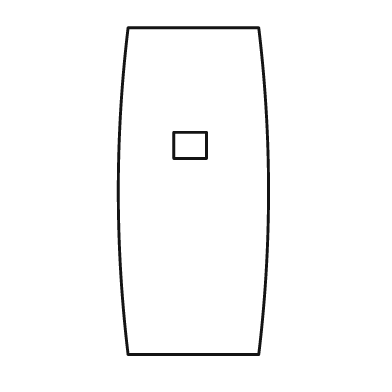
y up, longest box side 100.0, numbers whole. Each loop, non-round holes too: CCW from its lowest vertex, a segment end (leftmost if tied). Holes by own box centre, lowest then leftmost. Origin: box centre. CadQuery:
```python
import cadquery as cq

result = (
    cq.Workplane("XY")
    .moveTo(-20.0, -50.0)
    .lineTo(20.0, -50.0)
    .threePointArc((23.0, 0.0), (20.0, 50.0))
    .lineTo(-20.0, 50.0)
    .threePointArc((-23.0, 0.0), (-20.0, -50.0))
    .close()
    .moveTo(-6.0, 10.0)
    .lineTo(4.0, 10.0)
    .lineTo(4.0, 18.0)
    .lineTo(-6.0, 18.0)
    .close()
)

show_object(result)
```